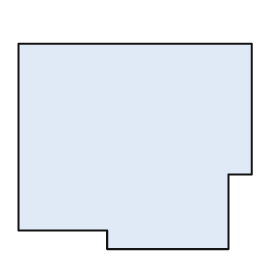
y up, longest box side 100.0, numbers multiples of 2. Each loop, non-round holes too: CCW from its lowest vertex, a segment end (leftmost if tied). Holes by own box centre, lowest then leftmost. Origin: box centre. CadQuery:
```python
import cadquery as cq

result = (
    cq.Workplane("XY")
    .moveTo(-12.0, -44.0)
    .lineTo(40.0, -44.0)
    .lineTo(40.0, -12.0)
    .lineTo(50.0, -12.0)
    .lineTo(50.0, 44.0)
    .lineTo(-50.0, 44.0)
    .lineTo(-50.0, -36.0)
    .lineTo(-12.0, -36.0)
    .close()
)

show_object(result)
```